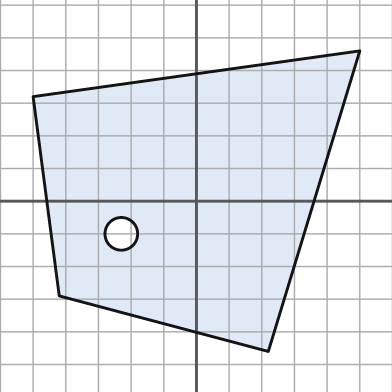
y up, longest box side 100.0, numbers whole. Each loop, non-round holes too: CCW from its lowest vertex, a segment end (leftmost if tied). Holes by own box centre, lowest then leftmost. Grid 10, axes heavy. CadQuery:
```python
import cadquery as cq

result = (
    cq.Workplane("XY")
    .moveTo(22.0, -46.0)
    .lineTo(50.0, 46.0)
    .lineTo(-50.0, 32.0)
    .lineTo(-42.0, -29.0)
    .close()
    .moveTo(-23.0, -10.0)
    .circle(5.0)
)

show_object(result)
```